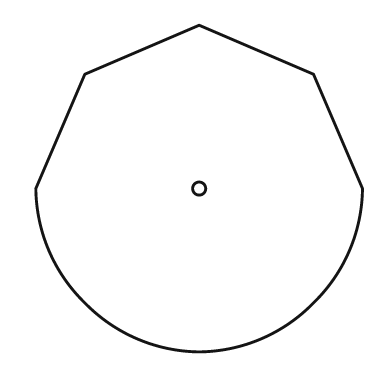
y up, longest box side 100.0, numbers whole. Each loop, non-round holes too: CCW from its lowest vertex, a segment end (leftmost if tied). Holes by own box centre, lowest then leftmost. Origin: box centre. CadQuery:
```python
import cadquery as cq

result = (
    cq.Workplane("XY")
    .moveTo(0.0, -50.0)
    .threePointArc((19.0, -46.0), (35.0, -35.0))
    .threePointArc((46.0, -19.0), (50.0, 0.0))
    .lineTo(35.0, 35.0)
    .lineTo(0.0, 50.0)
    .lineTo(-35.0, 35.0)
    .lineTo(-50.0, 0.0)
    .threePointArc((-46.0, -19.0), (-35.0, -35.0))
    .threePointArc((-19.0, -46.0), (0.0, -50.0))
    .close()
    .moveTo(0.0, 0.0)
    .circle(2.0)
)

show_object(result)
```